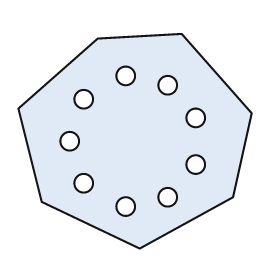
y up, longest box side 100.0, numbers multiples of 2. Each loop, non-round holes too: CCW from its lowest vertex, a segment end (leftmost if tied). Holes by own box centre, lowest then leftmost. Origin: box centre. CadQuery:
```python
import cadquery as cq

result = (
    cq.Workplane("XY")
    .moveTo(2.0, -46.0)
    .lineTo(42.0, -24.0)
    .lineTo(50.0, 12.0)
    .lineTo(20.0, 46.0)
    .lineTo(-16.0, 44.0)
    .lineTo(-50.0, 14.0)
    .lineTo(-40.0, -26.0)
    .close()
    .moveTo(-4.0, -28.0)
    .circle(4.0)
    .moveTo(14.0, -24.0)
    .circle(4.0)
    .moveTo(-22.0, -18.0)
    .circle(4.0)
    .moveTo(26.0, -10.0)
    .circle(4.0)
    .moveTo(-28.0, 0.0)
    .circle(4.0)
    .moveTo(26.0, 10.0)
    .circle(4.0)
    .moveTo(-22.0, 18.0)
    .circle(4.0)
    .moveTo(14.0, 24.0)
    .circle(4.0)
    .moveTo(-4.0, 28.0)
    .circle(4.0)
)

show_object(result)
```